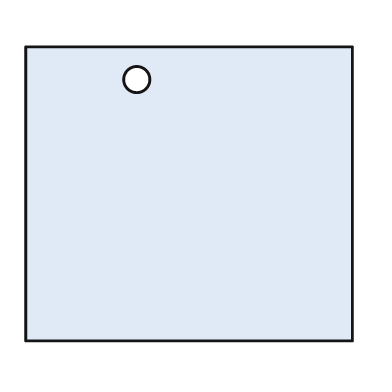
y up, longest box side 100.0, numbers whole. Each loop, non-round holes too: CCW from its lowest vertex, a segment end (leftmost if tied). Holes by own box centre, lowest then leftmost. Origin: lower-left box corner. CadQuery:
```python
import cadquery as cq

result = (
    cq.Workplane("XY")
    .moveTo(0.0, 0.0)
    .lineTo(100.0, 0.0)
    .lineTo(100.0, 90.0)
    .lineTo(0.0, 90.0)
    .close()
    .moveTo(34.0, 80.0)
    .circle(4.0)
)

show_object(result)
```